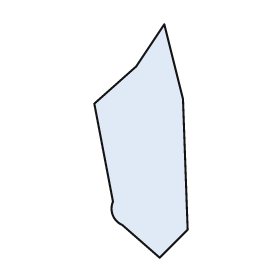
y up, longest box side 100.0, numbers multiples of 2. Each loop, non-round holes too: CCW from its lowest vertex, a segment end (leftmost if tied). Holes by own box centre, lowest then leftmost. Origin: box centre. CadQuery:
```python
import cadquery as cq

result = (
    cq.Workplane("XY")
    .moveTo(8.0, -50.0)
    .lineTo(20.0, -38.0)
    .lineTo(18.0, 18.0)
    .lineTo(10.0, 50.0)
    .lineTo(-2.0, 32.0)
    .lineTo(-20.0, 16.0)
    .lineTo(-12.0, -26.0)
    .threePointArc((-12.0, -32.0), (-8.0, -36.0))
    .close()
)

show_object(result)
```